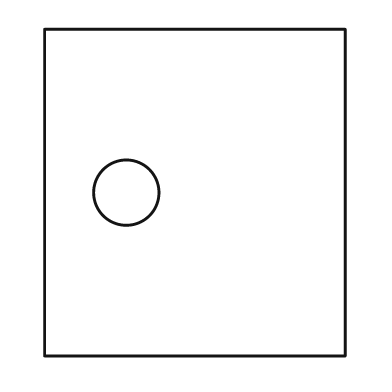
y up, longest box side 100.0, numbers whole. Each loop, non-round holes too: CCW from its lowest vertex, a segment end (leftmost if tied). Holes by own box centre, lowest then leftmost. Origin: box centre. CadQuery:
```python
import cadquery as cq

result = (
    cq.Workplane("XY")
    .moveTo(-46.0, -50.0)
    .lineTo(46.0, -50.0)
    .lineTo(46.0, 50.0)
    .lineTo(-46.0, 50.0)
    .close()
    .moveTo(-21.0, 0.0)
    .circle(10.0)
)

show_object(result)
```